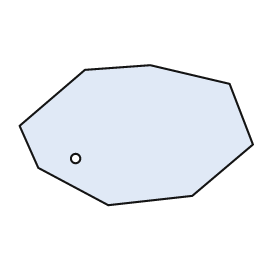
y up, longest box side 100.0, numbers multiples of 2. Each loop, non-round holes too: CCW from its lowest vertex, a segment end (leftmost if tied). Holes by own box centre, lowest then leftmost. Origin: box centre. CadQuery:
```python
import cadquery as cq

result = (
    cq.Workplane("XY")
    .moveTo(-12.0, -30.0)
    .lineTo(24.0, -26.0)
    .lineTo(50.0, -4.0)
    .lineTo(40.0, 22.0)
    .lineTo(6.0, 30.0)
    .lineTo(-22.0, 28.0)
    .lineTo(-50.0, 4.0)
    .lineTo(-42.0, -14.0)
    .close()
    .moveTo(-26.0, -10.0)
    .circle(2.0)
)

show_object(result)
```